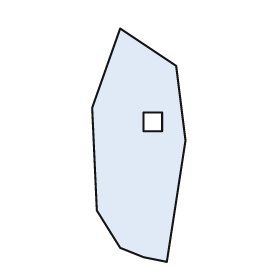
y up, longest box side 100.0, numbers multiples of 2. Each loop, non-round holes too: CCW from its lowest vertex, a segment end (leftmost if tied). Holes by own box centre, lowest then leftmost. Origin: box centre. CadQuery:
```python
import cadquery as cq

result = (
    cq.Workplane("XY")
    .moveTo(12.0, -50.0)
    .lineTo(20.0, 2.0)
    .lineTo(16.0, 34.0)
    .lineTo(-8.0, 50.0)
    .lineTo(-20.0, 16.0)
    .lineTo(-18.0, -28.0)
    .lineTo(-8.0, -44.0)
    .lineTo(2.0, -48.0)
    .close()
    .moveTo(2.0, 6.0)
    .lineTo(10.0, 6.0)
    .lineTo(10.0, 14.0)
    .lineTo(2.0, 14.0)
    .close()
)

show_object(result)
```